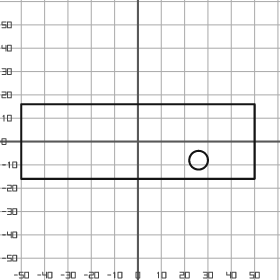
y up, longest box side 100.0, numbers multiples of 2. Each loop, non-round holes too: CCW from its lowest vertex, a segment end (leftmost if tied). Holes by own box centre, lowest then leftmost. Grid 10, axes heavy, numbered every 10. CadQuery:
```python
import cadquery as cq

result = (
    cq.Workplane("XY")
    .moveTo(-50.0, -16.0)
    .lineTo(50.0, -16.0)
    .lineTo(50.0, 16.0)
    .lineTo(-50.0, 16.0)
    .close()
    .moveTo(26.0, -8.0)
    .circle(4.0)
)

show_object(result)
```